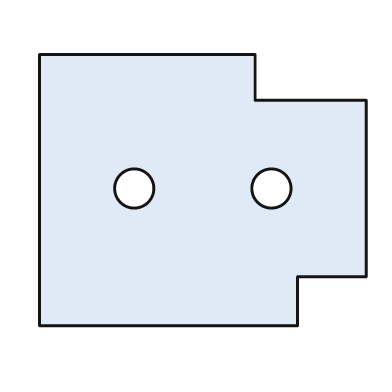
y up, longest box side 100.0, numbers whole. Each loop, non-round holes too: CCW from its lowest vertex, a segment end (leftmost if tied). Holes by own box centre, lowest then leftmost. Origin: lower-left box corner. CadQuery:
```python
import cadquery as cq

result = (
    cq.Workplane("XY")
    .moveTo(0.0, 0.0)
    .lineTo(79.0, 0.0)
    .lineTo(79.0, 15.0)
    .lineTo(100.0, 15.0)
    .lineTo(100.0, 69.0)
    .lineTo(66.0, 69.0)
    .lineTo(66.0, 83.0)
    .lineTo(0.0, 83.0)
    .close()
    .moveTo(29.0, 42.0)
    .circle(6.0)
    .moveTo(71.0, 42.0)
    .circle(6.0)
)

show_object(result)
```